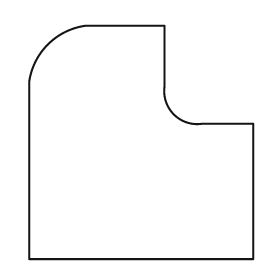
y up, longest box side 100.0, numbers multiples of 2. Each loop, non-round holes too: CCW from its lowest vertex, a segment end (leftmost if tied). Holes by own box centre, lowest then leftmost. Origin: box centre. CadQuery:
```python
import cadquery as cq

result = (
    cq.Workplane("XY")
    .moveTo(-48.0, -50.0)
    .lineTo(48.0, -50.0)
    .lineTo(48.0, 8.0)
    .lineTo(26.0, 8.0)
    .threePointArc((14.0, 12.0), (10.0, 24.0))
    .lineTo(10.0, 50.0)
    .lineTo(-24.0, 50.0)
    .threePointArc((-40.0, 42.0), (-48.0, 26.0))
    .close()
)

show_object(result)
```